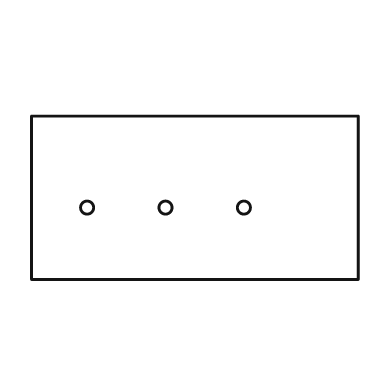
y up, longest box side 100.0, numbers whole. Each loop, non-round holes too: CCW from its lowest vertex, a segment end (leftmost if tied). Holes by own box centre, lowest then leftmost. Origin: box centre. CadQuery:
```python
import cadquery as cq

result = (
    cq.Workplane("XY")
    .moveTo(-50.0, -25.0)
    .lineTo(50.0, -25.0)
    .lineTo(50.0, 25.0)
    .lineTo(-50.0, 25.0)
    .close()
    .moveTo(-33.0, -3.0)
    .circle(2.0)
    .moveTo(-9.0, -3.0)
    .circle(2.0)
    .moveTo(15.0, -3.0)
    .circle(2.0)
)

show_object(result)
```